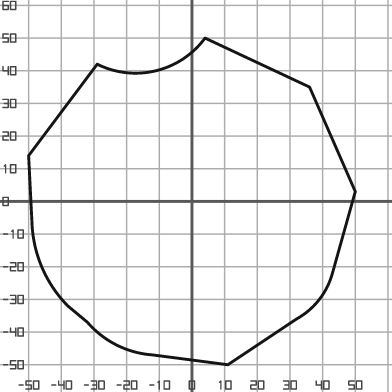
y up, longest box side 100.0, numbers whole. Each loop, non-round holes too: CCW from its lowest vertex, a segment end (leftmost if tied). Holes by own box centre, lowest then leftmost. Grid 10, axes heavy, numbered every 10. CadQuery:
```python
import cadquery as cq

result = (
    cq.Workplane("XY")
    .moveTo(11.0, -50.0)
    .lineTo(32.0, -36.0)
    .threePointArc((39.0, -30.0), (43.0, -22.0))
    .lineTo(50.0, 3.0)
    .lineTo(36.0, 35.0)
    .lineTo(4.0, 50.0)
    .threePointArc((-11.0, 40.0), (-29.0, 42.0))
    .lineTo(-50.0, 14.0)
    .lineTo(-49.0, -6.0)
    .threePointArc((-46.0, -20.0), (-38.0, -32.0))
    .lineTo(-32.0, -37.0)
    .threePointArc((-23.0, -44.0), (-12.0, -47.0))
    .close()
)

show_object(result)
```